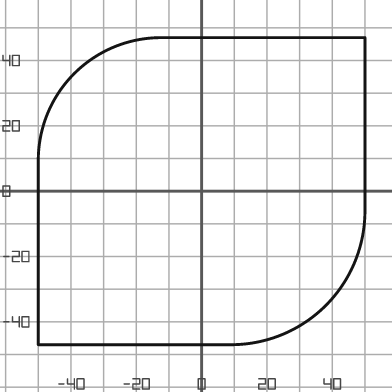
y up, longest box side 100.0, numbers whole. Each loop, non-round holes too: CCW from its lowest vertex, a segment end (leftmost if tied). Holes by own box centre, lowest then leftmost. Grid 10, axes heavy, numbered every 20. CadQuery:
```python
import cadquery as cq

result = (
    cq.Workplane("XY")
    .moveTo(-50.0, -47.0)
    .lineTo(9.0, -47.0)
    .threePointArc((38.0, -35.0), (50.0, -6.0))
    .lineTo(50.0, 47.0)
    .lineTo(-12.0, 47.0)
    .threePointArc((-39.0, 36.0), (-50.0, 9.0))
    .close()
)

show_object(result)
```